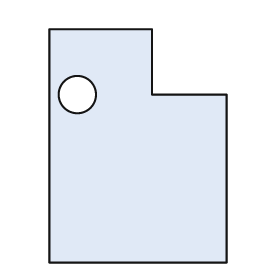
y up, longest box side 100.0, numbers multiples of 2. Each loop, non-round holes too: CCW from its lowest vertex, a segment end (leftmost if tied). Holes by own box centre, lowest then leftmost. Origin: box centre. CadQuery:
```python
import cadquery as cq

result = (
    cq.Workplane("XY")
    .moveTo(-38.0, -50.0)
    .lineTo(38.0, -50.0)
    .lineTo(38.0, 22.0)
    .lineTo(6.0, 22.0)
    .lineTo(6.0, 50.0)
    .lineTo(-38.0, 50.0)
    .close()
    .moveTo(-26.0, 22.0)
    .circle(8.0)
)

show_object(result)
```